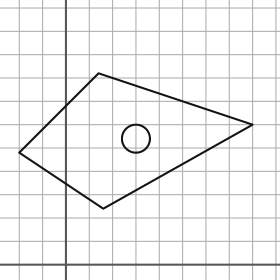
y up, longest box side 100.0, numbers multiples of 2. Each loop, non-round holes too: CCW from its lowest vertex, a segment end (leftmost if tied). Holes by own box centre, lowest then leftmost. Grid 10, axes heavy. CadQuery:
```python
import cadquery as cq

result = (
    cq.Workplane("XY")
    .moveTo(16.0, 24.0)
    .lineTo(80.0, 60.0)
    .lineTo(14.0, 82.0)
    .lineTo(-20.0, 48.0)
    .close()
    .moveTo(30.0, 54.0)
    .circle(6.0)
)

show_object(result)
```